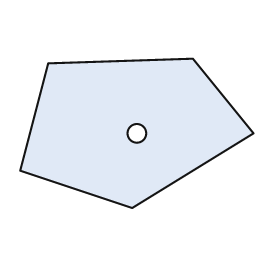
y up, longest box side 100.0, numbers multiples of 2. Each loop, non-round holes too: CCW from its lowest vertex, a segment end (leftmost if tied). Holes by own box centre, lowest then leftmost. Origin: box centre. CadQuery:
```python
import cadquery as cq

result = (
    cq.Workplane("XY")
    .moveTo(-2.0, -32.0)
    .lineTo(50.0, 0.0)
    .lineTo(24.0, 32.0)
    .lineTo(-38.0, 30.0)
    .lineTo(-50.0, -16.0)
    .close()
    .moveTo(0.0, 0.0)
    .circle(4.0)
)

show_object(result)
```